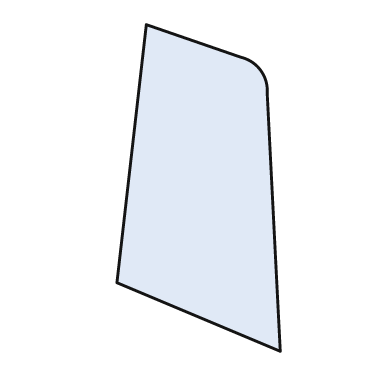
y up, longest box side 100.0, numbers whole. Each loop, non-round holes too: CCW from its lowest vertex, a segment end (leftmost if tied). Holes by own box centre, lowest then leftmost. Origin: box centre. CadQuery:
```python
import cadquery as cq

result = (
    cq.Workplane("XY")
    .moveTo(25.0, -50.0)
    .lineTo(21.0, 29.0)
    .threePointArc((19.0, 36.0), (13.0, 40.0))
    .lineTo(-16.0, 50.0)
    .lineTo(-25.0, -29.0)
    .close()
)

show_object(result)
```